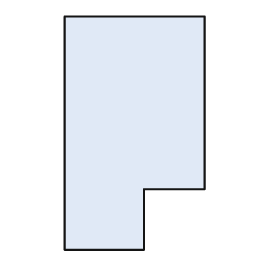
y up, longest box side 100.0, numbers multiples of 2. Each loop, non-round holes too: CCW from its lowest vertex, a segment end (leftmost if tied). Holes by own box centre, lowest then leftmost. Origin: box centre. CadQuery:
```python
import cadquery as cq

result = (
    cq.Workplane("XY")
    .moveTo(-30.0, -50.0)
    .lineTo(4.0, -50.0)
    .lineTo(4.0, -24.0)
    .lineTo(30.0, -24.0)
    .lineTo(30.0, 50.0)
    .lineTo(-30.0, 50.0)
    .close()
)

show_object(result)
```